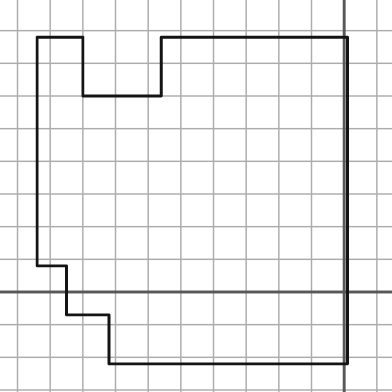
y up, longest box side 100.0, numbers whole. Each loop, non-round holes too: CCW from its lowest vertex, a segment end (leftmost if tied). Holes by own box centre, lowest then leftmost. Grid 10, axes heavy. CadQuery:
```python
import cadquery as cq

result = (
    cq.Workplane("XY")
    .moveTo(-72.0, -22.0)
    .lineTo(1.0, -22.0)
    .lineTo(1.0, 78.0)
    .lineTo(-56.0, 78.0)
    .lineTo(-56.0, 60.0)
    .lineTo(-80.0, 60.0)
    .lineTo(-80.0, 78.0)
    .lineTo(-94.0, 78.0)
    .lineTo(-94.0, 8.0)
    .lineTo(-85.0, 8.0)
    .lineTo(-85.0, -7.0)
    .lineTo(-72.0, -7.0)
    .close()
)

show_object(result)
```